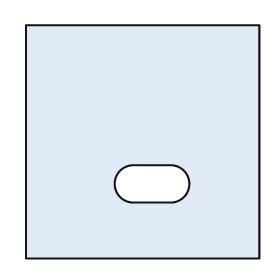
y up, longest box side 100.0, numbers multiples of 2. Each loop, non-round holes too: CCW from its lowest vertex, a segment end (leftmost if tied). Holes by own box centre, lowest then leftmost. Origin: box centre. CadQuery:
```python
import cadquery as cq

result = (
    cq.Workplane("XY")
    .moveTo(-50.0, -50.0)
    .lineTo(50.0, -50.0)
    .lineTo(50.0, 50.0)
    .lineTo(-50.0, 50.0)
    .close()
    .moveTo(-4.0, -26.0)
    .lineTo(12.0, -26.0)
    .threePointArc((20.0, -18.0), (12.0, -10.0))
    .lineTo(-4.0, -10.0)
    .threePointArc((-12.0, -18.0), (-4.0, -26.0))
    .close()
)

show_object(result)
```